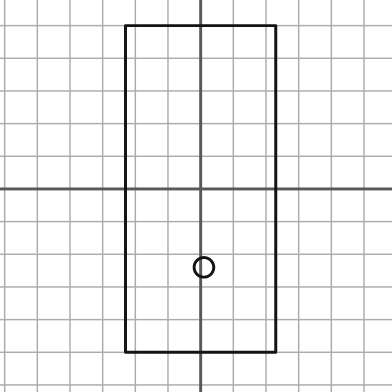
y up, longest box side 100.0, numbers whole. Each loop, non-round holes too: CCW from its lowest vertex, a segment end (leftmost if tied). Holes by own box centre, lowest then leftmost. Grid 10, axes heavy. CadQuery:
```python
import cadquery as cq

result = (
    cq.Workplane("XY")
    .moveTo(-23.0, -50.0)
    .lineTo(23.0, -50.0)
    .lineTo(23.0, 50.0)
    .lineTo(-23.0, 50.0)
    .close()
    .moveTo(1.0, -24.0)
    .circle(3.0)
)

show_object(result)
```